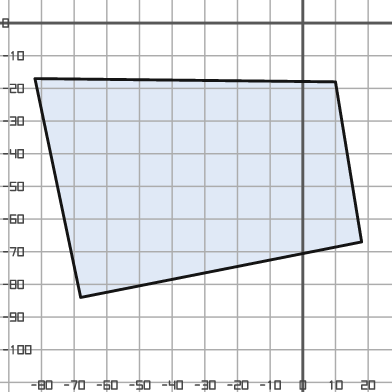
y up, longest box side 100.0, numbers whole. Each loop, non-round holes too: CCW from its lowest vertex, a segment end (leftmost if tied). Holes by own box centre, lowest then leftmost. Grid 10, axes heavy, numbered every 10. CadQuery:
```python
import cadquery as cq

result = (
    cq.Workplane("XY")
    .moveTo(-68.0, -84.0)
    .lineTo(18.0, -67.0)
    .lineTo(10.0, -18.0)
    .lineTo(-82.0, -17.0)
    .close()
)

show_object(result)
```